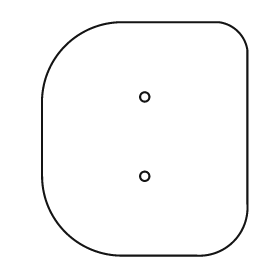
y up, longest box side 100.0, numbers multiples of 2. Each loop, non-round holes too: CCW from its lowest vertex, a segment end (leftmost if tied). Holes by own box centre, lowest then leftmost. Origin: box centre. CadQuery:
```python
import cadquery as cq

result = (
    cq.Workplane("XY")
    .moveTo(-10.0, -50.0)
    .lineTo(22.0, -50.0)
    .threePointArc((38.0, -44.0), (44.0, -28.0))
    .lineTo(44.0, 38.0)
    .threePointArc((40.0, 46.0), (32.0, 50.0))
    .lineTo(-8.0, 50.0)
    .threePointArc((-34.0, 40.0), (-44.0, 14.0))
    .lineTo(-44.0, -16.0)
    .threePointArc((-34.0, -40.0), (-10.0, -50.0))
    .close()
    .moveTo(0.0, -16.0)
    .circle(2.0)
    .moveTo(0.0, 18.0)
    .circle(2.0)
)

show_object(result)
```